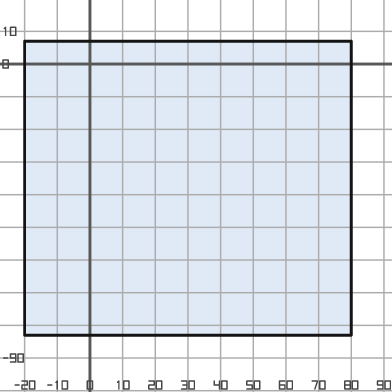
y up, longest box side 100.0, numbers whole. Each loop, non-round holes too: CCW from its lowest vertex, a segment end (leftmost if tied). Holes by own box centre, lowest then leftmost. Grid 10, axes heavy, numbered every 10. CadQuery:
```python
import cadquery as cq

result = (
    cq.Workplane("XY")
    .moveTo(-20.0, -83.0)
    .lineTo(80.0, -83.0)
    .lineTo(80.0, 7.0)
    .lineTo(-20.0, 7.0)
    .close()
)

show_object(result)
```